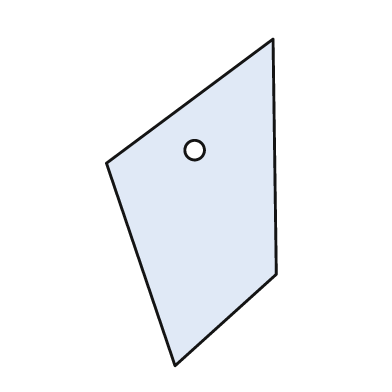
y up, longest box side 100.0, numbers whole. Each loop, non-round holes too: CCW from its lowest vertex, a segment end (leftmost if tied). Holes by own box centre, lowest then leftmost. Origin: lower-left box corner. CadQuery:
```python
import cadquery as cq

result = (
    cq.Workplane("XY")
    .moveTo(21.0, 0.0)
    .lineTo(52.0, 28.0)
    .lineTo(51.0, 100.0)
    .lineTo(0.0, 62.0)
    .close()
    .moveTo(27.0, 66.0)
    .circle(3.0)
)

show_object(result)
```